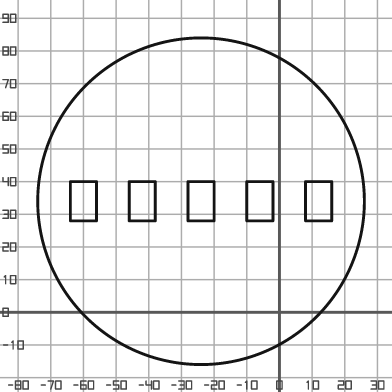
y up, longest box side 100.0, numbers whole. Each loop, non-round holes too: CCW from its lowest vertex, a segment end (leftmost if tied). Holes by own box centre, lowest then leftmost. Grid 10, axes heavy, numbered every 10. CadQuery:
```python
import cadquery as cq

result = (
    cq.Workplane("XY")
    .moveTo(-24.0, 34.0)
    .circle(50.0)
    .moveTo(-64.0, 28.0)
    .lineTo(-56.0, 28.0)
    .lineTo(-56.0, 40.0)
    .lineTo(-64.0, 40.0)
    .close()
    .moveTo(-46.0, 28.0)
    .lineTo(-38.0, 28.0)
    .lineTo(-38.0, 40.0)
    .lineTo(-46.0, 40.0)
    .close()
    .moveTo(-28.0, 28.0)
    .lineTo(-20.0, 28.0)
    .lineTo(-20.0, 40.0)
    .lineTo(-28.0, 40.0)
    .close()
    .moveTo(-10.0, 28.0)
    .lineTo(-2.0, 28.0)
    .lineTo(-2.0, 40.0)
    .lineTo(-10.0, 40.0)
    .close()
    .moveTo(8.0, 28.0)
    .lineTo(16.0, 28.0)
    .lineTo(16.0, 40.0)
    .lineTo(8.0, 40.0)
    .close()
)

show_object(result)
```